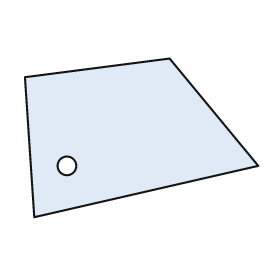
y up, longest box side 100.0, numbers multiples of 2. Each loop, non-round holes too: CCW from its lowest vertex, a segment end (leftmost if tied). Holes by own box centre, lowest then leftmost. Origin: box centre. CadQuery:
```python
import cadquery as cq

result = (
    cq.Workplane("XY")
    .moveTo(-46.0, -34.0)
    .lineTo(50.0, -12.0)
    .lineTo(12.0, 34.0)
    .lineTo(-50.0, 26.0)
    .close()
    .moveTo(-32.0, -12.0)
    .circle(4.0)
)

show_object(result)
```